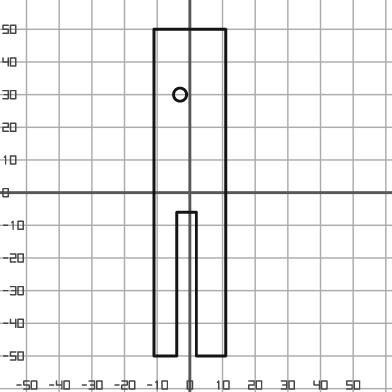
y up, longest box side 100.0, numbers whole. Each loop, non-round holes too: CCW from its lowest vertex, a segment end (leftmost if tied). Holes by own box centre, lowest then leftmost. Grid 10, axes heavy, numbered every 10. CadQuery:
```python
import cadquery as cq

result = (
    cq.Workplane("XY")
    .moveTo(-11.0, -50.0)
    .lineTo(-4.0, -50.0)
    .lineTo(-4.0, -6.0)
    .lineTo(2.0, -6.0)
    .lineTo(2.0, -50.0)
    .lineTo(11.0, -50.0)
    .lineTo(11.0, 50.0)
    .lineTo(-11.0, 50.0)
    .close()
    .moveTo(-3.0, 30.0)
    .circle(2.0)
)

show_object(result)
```